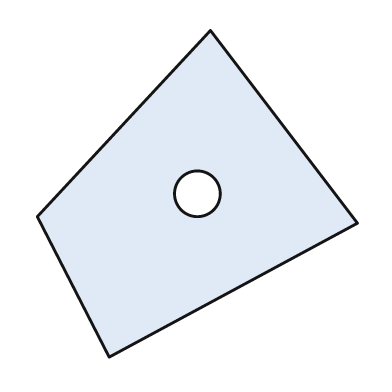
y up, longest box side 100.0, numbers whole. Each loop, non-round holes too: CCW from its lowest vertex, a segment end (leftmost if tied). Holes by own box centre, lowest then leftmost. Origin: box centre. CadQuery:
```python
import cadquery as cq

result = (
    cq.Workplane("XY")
    .moveTo(-27.0, -50.0)
    .lineTo(49.0, -9.0)
    .lineTo(4.0, 50.0)
    .lineTo(-49.0, -7.0)
    .close()
    .moveTo(0.0, 0.0)
    .circle(7.0)
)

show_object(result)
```